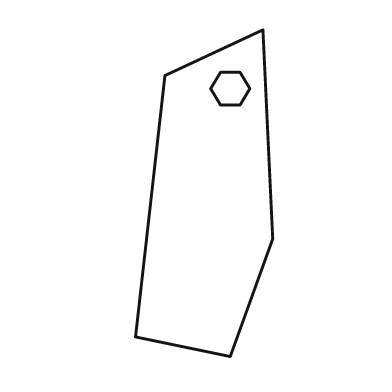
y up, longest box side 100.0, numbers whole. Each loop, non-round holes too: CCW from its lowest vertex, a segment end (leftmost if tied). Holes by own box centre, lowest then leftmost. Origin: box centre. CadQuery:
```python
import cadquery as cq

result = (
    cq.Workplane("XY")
    .moveTo(8.0, -50.0)
    .lineTo(21.0, -14.0)
    .lineTo(18.0, 50.0)
    .lineTo(-12.0, 36.0)
    .lineTo(-21.0, -44.0)
    .close()
    .moveTo(5.0, 27.0)
    .lineTo(11.0, 27.0)
    .lineTo(14.0, 32.0)
    .lineTo(11.0, 37.0)
    .lineTo(5.0, 37.0)
    .lineTo(2.0, 32.0)
    .close()
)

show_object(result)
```